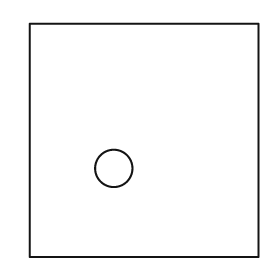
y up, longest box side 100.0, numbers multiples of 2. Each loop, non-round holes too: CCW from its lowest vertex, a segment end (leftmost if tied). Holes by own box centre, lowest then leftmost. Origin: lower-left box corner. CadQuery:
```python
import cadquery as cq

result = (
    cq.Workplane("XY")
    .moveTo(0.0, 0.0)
    .lineTo(98.0, 0.0)
    .lineTo(98.0, 100.0)
    .lineTo(0.0, 100.0)
    .close()
    .moveTo(36.0, 38.0)
    .circle(8.0)
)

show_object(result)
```